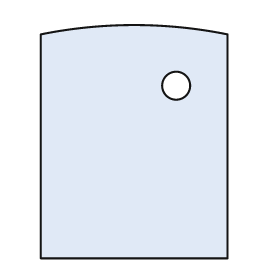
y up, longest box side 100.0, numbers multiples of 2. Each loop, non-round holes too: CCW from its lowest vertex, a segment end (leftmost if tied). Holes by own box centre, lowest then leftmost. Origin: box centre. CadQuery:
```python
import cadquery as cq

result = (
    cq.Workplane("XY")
    .moveTo(-40.0, -50.0)
    .lineTo(40.0, -50.0)
    .lineTo(40.0, 46.0)
    .threePointArc((0.0, 50.0), (-40.0, 46.0))
    .close()
    .moveTo(18.0, 24.0)
    .circle(6.0)
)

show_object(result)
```